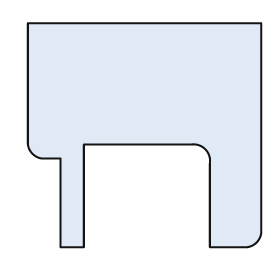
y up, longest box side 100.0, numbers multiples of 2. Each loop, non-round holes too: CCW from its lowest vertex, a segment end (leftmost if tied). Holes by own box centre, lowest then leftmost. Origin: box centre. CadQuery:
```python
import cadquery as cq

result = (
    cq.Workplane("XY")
    .moveTo(-36.0, -48.0)
    .lineTo(-26.0, -48.0)
    .lineTo(-26.0, -4.0)
    .lineTo(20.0, -4.0)
    .threePointArc((26.0, -6.0), (28.0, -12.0))
    .lineTo(28.0, -48.0)
    .lineTo(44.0, -48.0)
    .threePointArc((48.0, -46.0), (50.0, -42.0))
    .lineTo(50.0, 48.0)
    .lineTo(-50.0, 48.0)
    .lineTo(-50.0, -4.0)
    .threePointArc((-48.0, -8.0), (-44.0, -10.0))
    .lineTo(-36.0, -10.0)
    .close()
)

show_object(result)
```